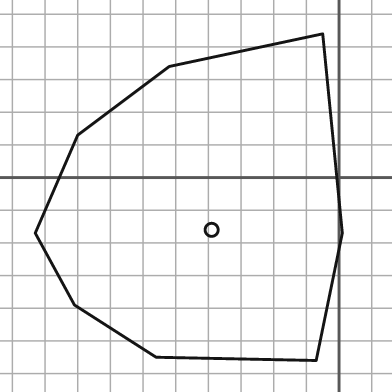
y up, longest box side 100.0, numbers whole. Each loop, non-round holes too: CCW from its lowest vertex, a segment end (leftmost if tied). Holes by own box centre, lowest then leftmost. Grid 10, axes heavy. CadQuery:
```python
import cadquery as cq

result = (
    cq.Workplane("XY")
    .moveTo(-7.0, -56.0)
    .lineTo(1.0, -17.0)
    .lineTo(-5.0, 44.0)
    .lineTo(-52.0, 34.0)
    .lineTo(-80.0, 13.0)
    .lineTo(-93.0, -17.0)
    .lineTo(-81.0, -39.0)
    .lineTo(-56.0, -55.0)
    .close()
    .moveTo(-39.0, -16.0)
    .circle(2.0)
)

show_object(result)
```